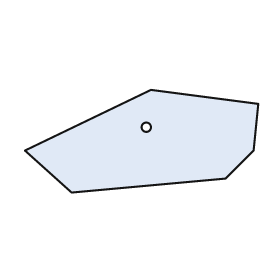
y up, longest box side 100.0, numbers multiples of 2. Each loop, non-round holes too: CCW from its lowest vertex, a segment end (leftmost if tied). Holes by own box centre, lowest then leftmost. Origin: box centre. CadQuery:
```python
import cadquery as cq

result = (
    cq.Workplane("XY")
    .moveTo(-30.0, -22.0)
    .lineTo(36.0, -16.0)
    .lineTo(48.0, -4.0)
    .lineTo(50.0, 16.0)
    .lineTo(4.0, 22.0)
    .lineTo(-50.0, -4.0)
    .close()
    .moveTo(2.0, 6.0)
    .circle(2.0)
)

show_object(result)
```